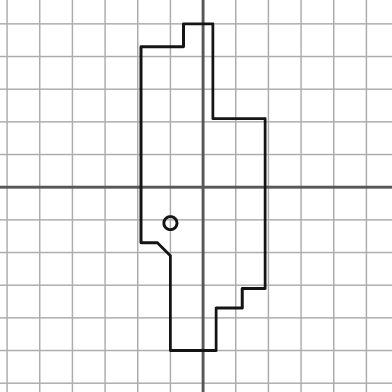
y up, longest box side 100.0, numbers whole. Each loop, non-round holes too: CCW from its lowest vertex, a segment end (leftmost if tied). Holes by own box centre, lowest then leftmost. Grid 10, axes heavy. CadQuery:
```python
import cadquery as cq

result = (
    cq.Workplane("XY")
    .moveTo(-10.0, -50.0)
    .lineTo(4.0, -50.0)
    .lineTo(4.0, -37.0)
    .lineTo(12.0, -37.0)
    .lineTo(12.0, -31.0)
    .lineTo(19.0, -31.0)
    .lineTo(19.0, 21.0)
    .lineTo(3.0, 21.0)
    .lineTo(3.0, 50.0)
    .lineTo(-6.0, 50.0)
    .lineTo(-6.0, 43.0)
    .lineTo(-19.0, 43.0)
    .lineTo(-19.0, -17.0)
    .lineTo(-14.0, -17.0)
    .lineTo(-10.0, -21.0)
    .close()
    .moveTo(-10.0, -11.0)
    .circle(2.0)
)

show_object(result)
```